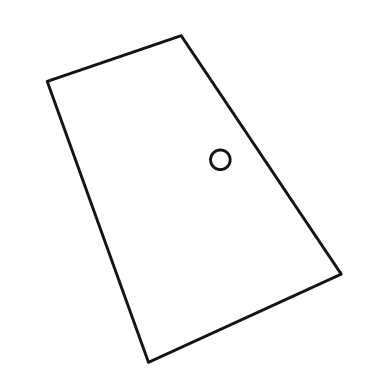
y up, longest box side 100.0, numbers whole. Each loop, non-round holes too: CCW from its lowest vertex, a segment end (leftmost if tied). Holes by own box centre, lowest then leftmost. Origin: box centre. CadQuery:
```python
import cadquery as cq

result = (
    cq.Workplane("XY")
    .moveTo(-14.0, -50.0)
    .lineTo(45.0, -23.0)
    .lineTo(-4.0, 50.0)
    .lineTo(-45.0, 36.0)
    .close()
    .moveTo(8.0, 12.0)
    .circle(3.0)
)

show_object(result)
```